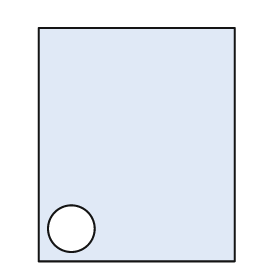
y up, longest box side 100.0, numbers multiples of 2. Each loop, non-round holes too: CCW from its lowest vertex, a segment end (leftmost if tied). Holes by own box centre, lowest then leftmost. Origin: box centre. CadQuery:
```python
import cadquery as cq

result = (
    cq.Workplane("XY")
    .moveTo(-42.0, -50.0)
    .lineTo(42.0, -50.0)
    .lineTo(42.0, 50.0)
    .lineTo(-42.0, 50.0)
    .close()
    .moveTo(-28.0, -36.0)
    .circle(10.0)
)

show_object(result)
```